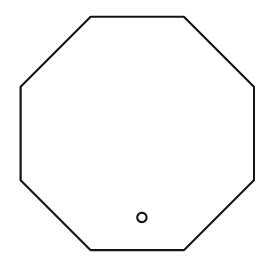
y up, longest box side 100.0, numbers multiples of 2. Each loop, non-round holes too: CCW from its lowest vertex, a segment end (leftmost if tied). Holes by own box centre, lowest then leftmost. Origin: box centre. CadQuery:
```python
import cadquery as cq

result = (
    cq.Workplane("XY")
    .moveTo(-20.0, -50.0)
    .lineTo(20.0, -50.0)
    .lineTo(50.0, -20.0)
    .lineTo(50.0, 20.0)
    .lineTo(20.0, 50.0)
    .lineTo(-20.0, 50.0)
    .lineTo(-50.0, 20.0)
    .lineTo(-50.0, -20.0)
    .close()
    .moveTo(2.0, -36.0)
    .circle(2.0)
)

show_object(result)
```